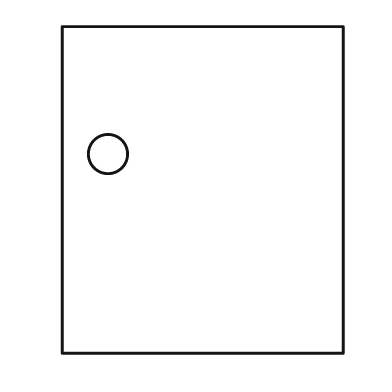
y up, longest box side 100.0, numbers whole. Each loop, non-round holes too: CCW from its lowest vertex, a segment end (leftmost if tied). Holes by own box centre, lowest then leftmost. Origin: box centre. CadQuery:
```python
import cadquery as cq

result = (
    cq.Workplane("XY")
    .moveTo(-43.0, -50.0)
    .lineTo(43.0, -50.0)
    .lineTo(43.0, 50.0)
    .lineTo(-43.0, 50.0)
    .close()
    .moveTo(-29.0, 11.0)
    .circle(6.0)
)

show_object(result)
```